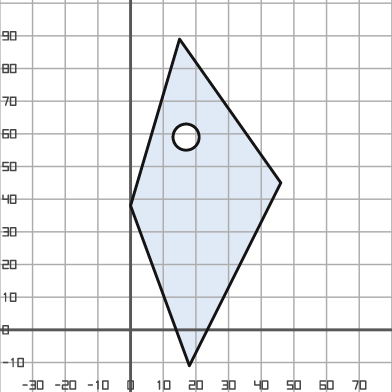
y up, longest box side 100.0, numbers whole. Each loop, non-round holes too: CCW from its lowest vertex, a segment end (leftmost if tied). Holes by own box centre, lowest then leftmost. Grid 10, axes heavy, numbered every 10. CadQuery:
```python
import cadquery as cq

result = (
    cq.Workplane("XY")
    .moveTo(18.0, -11.0)
    .lineTo(46.0, 45.0)
    .lineTo(15.0, 89.0)
    .lineTo(0.0, 38.0)
    .close()
    .moveTo(17.0, 59.0)
    .circle(4.0)
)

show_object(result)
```